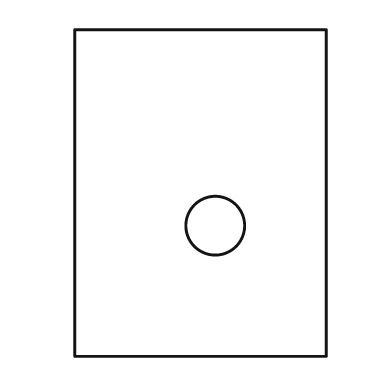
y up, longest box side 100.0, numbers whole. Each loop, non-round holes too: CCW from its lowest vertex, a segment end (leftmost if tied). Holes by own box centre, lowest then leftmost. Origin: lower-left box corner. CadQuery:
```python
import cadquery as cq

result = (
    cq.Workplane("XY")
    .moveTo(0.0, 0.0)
    .lineTo(77.0, 0.0)
    .lineTo(77.0, 100.0)
    .lineTo(0.0, 100.0)
    .close()
    .moveTo(43.0, 40.0)
    .circle(9.0)
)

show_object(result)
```